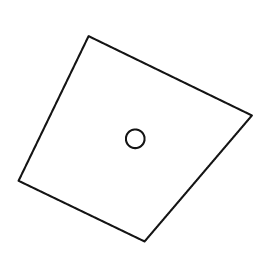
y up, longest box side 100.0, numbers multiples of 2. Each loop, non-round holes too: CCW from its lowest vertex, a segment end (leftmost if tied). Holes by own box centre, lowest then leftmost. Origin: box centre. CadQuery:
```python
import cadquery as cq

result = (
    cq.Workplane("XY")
    .moveTo(4.0, -44.0)
    .lineTo(50.0, 10.0)
    .lineTo(-20.0, 44.0)
    .lineTo(-50.0, -18.0)
    .close()
    .moveTo(0.0, 0.0)
    .circle(4.0)
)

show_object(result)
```